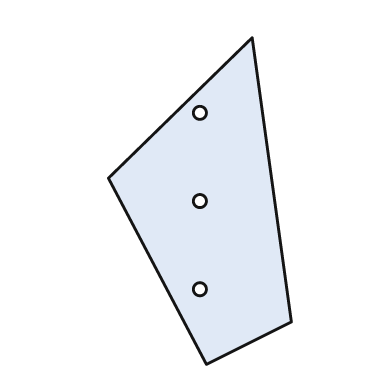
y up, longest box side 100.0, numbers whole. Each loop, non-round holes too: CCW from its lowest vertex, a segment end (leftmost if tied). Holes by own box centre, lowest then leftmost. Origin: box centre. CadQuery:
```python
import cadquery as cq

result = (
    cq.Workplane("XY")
    .moveTo(2.0, -50.0)
    .lineTo(28.0, -37.0)
    .lineTo(16.0, 50.0)
    .lineTo(-28.0, 7.0)
    .close()
    .moveTo(0.0, -27.0)
    .circle(2.0)
    .moveTo(0.0, 0.0)
    .circle(2.0)
    .moveTo(0.0, 27.0)
    .circle(2.0)
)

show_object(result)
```